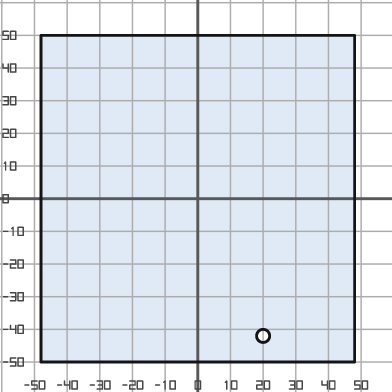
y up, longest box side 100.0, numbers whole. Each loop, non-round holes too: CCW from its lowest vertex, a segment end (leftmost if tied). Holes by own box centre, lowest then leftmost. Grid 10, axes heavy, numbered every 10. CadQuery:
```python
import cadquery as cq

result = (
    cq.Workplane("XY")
    .moveTo(-48.0, -50.0)
    .lineTo(48.0, -50.0)
    .lineTo(48.0, 50.0)
    .lineTo(-48.0, 50.0)
    .close()
    .moveTo(20.0, -42.0)
    .circle(2.0)
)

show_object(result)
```